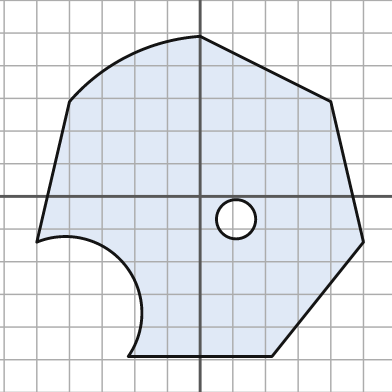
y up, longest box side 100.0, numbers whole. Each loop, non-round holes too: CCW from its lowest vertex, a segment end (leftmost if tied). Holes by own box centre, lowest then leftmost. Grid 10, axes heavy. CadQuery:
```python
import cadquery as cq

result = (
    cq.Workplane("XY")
    .moveTo(-22.0, -49.0)
    .lineTo(22.0, -49.0)
    .lineTo(50.0, -14.0)
    .lineTo(40.0, 29.0)
    .lineTo(0.0, 49.0)
    .threePointArc((-22.0, 43.0), (-40.0, 29.0))
    .lineTo(-50.0, -14.0)
    .threePointArc((-23.0, -21.0), (-22.0, -49.0))
    .close()
    .moveTo(11.0, -7.0)
    .circle(6.0)
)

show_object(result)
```